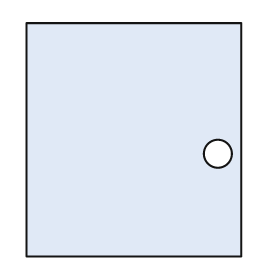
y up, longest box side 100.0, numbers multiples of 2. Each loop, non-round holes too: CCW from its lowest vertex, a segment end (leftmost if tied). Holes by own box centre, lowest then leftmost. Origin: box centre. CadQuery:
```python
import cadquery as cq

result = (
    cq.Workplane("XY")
    .moveTo(-46.0, -50.0)
    .lineTo(46.0, -50.0)
    .lineTo(46.0, 50.0)
    .lineTo(-46.0, 50.0)
    .close()
    .moveTo(36.0, -6.0)
    .circle(6.0)
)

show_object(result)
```